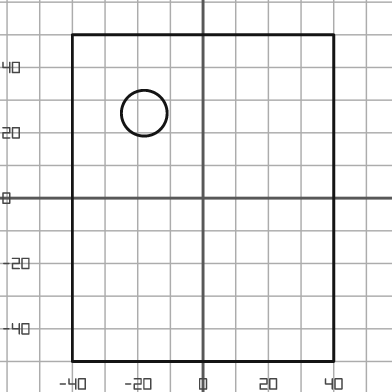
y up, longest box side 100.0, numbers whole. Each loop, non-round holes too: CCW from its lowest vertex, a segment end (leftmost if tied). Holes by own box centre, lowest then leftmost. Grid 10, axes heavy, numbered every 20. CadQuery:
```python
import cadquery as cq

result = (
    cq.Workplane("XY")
    .moveTo(-40.0, -50.0)
    .lineTo(40.0, -50.0)
    .lineTo(40.0, 50.0)
    .lineTo(-40.0, 50.0)
    .close()
    .moveTo(-18.0, 26.0)
    .circle(7.0)
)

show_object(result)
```